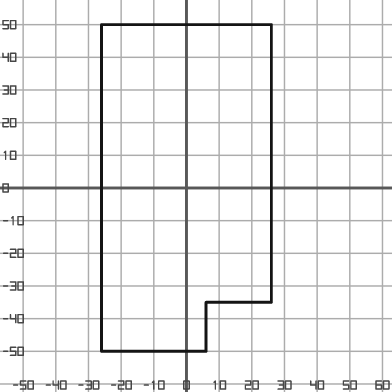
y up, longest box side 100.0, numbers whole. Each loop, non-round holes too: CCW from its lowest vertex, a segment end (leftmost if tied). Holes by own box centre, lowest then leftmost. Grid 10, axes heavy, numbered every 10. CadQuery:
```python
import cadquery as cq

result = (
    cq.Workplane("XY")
    .moveTo(-26.0, -50.0)
    .lineTo(6.0, -50.0)
    .lineTo(6.0, -35.0)
    .lineTo(26.0, -35.0)
    .lineTo(26.0, 50.0)
    .lineTo(-26.0, 50.0)
    .close()
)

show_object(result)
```